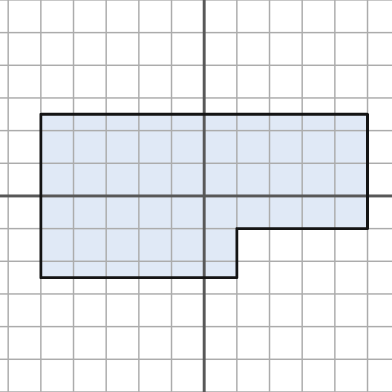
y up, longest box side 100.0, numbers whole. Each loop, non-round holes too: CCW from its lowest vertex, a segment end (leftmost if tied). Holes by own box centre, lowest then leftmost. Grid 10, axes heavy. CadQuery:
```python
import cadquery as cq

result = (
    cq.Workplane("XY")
    .moveTo(-50.0, -25.0)
    .lineTo(10.0, -25.0)
    .lineTo(10.0, -10.0)
    .lineTo(50.0, -10.0)
    .lineTo(50.0, 25.0)
    .lineTo(-50.0, 25.0)
    .close()
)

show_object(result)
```